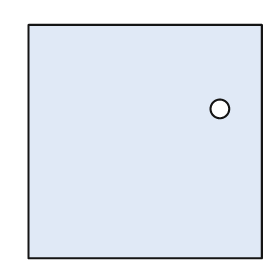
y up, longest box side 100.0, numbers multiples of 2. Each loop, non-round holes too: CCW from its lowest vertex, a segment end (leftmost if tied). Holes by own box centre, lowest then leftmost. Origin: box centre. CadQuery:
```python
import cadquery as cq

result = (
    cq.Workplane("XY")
    .moveTo(-50.0, -50.0)
    .lineTo(50.0, -50.0)
    .lineTo(50.0, 50.0)
    .lineTo(-50.0, 50.0)
    .close()
    .moveTo(32.0, 14.0)
    .circle(4.0)
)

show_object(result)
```